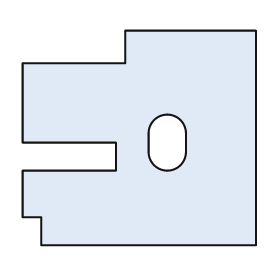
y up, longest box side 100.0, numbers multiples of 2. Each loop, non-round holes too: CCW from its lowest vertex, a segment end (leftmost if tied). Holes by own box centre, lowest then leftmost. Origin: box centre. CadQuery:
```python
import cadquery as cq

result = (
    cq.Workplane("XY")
    .moveTo(-42.0, -46.0)
    .lineTo(50.0, -46.0)
    .lineTo(50.0, 46.0)
    .lineTo(-6.0, 46.0)
    .lineTo(-6.0, 32.0)
    .lineTo(-50.0, 32.0)
    .lineTo(-50.0, -2.0)
    .lineTo(-10.0, -2.0)
    .lineTo(-10.0, -14.0)
    .lineTo(-50.0, -14.0)
    .lineTo(-50.0, -34.0)
    .lineTo(-42.0, -34.0)
    .close()
    .moveTo(4.0, -6.0)
    .threePointArc((12.0, -14.0), (20.0, -6.0))
    .lineTo(20.0, 2.0)
    .threePointArc((12.0, 10.0), (4.0, 2.0))
    .close()
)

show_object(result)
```